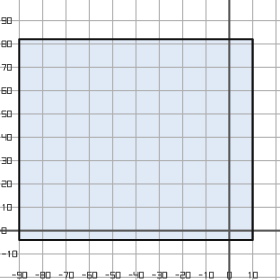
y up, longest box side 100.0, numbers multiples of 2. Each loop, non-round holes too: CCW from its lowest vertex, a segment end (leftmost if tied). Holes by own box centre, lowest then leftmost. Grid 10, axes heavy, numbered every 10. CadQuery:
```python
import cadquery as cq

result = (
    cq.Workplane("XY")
    .moveTo(-90.0, -4.0)
    .lineTo(10.0, -4.0)
    .lineTo(10.0, 82.0)
    .lineTo(-90.0, 82.0)
    .close()
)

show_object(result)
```